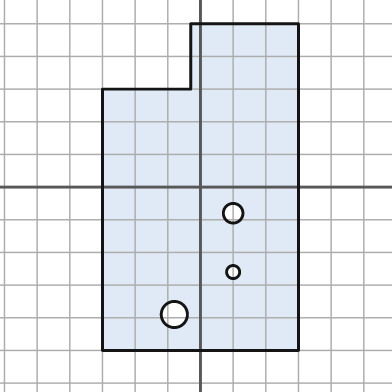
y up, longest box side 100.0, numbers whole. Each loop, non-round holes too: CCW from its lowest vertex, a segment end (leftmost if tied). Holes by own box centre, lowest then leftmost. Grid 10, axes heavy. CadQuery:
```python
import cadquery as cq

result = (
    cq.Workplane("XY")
    .moveTo(-30.0, -50.0)
    .lineTo(30.0, -50.0)
    .lineTo(30.0, 50.0)
    .lineTo(-3.0, 50.0)
    .lineTo(-3.0, 30.0)
    .lineTo(-30.0, 30.0)
    .close()
    .moveTo(-8.0, -39.0)
    .circle(4.0)
    .moveTo(10.0, -26.0)
    .circle(2.0)
    .moveTo(10.0, -8.0)
    .circle(3.0)
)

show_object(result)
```